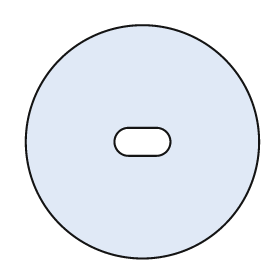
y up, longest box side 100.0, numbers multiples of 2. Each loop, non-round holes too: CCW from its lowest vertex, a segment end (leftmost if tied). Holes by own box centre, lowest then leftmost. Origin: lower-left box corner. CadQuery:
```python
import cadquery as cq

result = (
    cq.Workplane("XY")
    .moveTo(50.0, 50.0)
    .circle(50.0)
    .moveTo(44.0, 44.0)
    .lineTo(56.0, 44.0)
    .threePointArc((62.0, 50.0), (56.0, 56.0))
    .lineTo(44.0, 56.0)
    .threePointArc((38.0, 50.0), (44.0, 44.0))
    .close()
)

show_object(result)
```